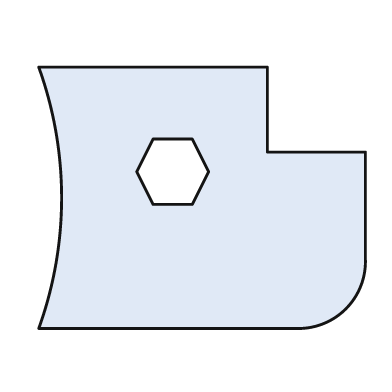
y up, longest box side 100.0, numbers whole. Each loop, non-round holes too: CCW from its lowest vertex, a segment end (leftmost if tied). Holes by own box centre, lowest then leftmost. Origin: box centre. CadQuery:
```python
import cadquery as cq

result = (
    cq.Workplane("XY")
    .moveTo(-50.0, -40.0)
    .lineTo(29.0, -40.0)
    .threePointArc((44.0, -34.0), (50.0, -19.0))
    .lineTo(50.0, 14.0)
    .lineTo(20.0, 14.0)
    .lineTo(20.0, 40.0)
    .lineTo(-50.0, 40.0)
    .threePointArc((-43.0, 0.0), (-50.0, -40.0))
    .close()
    .moveTo(-15.0, -2.0)
    .lineTo(-3.0, -2.0)
    .lineTo(2.0, 8.0)
    .lineTo(-3.0, 18.0)
    .lineTo(-15.0, 18.0)
    .lineTo(-20.0, 8.0)
    .close()
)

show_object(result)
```